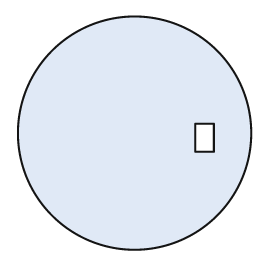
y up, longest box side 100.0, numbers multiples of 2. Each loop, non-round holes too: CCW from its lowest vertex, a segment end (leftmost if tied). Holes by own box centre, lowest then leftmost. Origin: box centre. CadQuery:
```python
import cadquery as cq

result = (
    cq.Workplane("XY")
    .moveTo(0.0, 0.0)
    .circle(50.0)
    .moveTo(26.0, -8.0)
    .lineTo(34.0, -8.0)
    .lineTo(34.0, 4.0)
    .lineTo(26.0, 4.0)
    .close()
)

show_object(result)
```